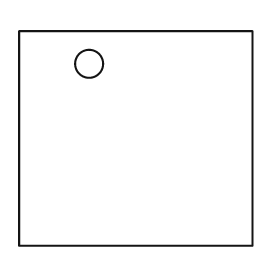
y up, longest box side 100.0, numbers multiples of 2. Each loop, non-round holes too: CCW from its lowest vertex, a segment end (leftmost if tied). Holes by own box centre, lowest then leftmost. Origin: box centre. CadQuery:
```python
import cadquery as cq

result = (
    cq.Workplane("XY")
    .moveTo(-50.0, -46.0)
    .lineTo(50.0, -46.0)
    .lineTo(50.0, 46.0)
    .lineTo(-50.0, 46.0)
    .close()
    .moveTo(-20.0, 32.0)
    .circle(6.0)
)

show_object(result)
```